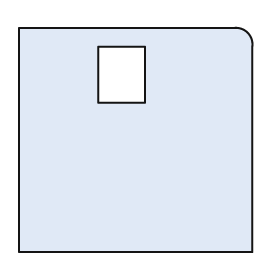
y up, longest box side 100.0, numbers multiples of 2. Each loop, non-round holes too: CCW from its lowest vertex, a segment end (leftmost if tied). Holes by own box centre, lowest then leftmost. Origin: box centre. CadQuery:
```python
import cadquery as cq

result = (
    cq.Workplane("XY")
    .moveTo(-50.0, -48.0)
    .lineTo(50.0, -48.0)
    .lineTo(50.0, 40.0)
    .threePointArc((48.0, 46.0), (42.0, 48.0))
    .lineTo(-50.0, 48.0)
    .close()
    .moveTo(-16.0, 16.0)
    .lineTo(4.0, 16.0)
    .lineTo(4.0, 40.0)
    .lineTo(-16.0, 40.0)
    .close()
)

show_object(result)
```